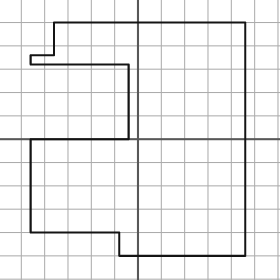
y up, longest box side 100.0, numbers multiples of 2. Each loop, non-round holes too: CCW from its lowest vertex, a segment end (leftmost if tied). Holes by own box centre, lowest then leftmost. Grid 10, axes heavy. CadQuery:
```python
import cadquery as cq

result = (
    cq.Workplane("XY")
    .moveTo(-8.0, -50.0)
    .lineTo(46.0, -50.0)
    .lineTo(46.0, 50.0)
    .lineTo(-36.0, 50.0)
    .lineTo(-36.0, 36.0)
    .lineTo(-46.0, 36.0)
    .lineTo(-46.0, 32.0)
    .lineTo(-4.0, 32.0)
    .lineTo(-4.0, 0.0)
    .lineTo(-46.0, 0.0)
    .lineTo(-46.0, -40.0)
    .lineTo(-8.0, -40.0)
    .close()
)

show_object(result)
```